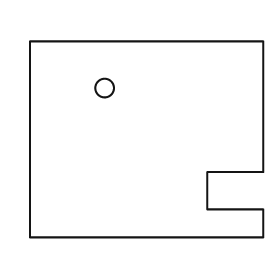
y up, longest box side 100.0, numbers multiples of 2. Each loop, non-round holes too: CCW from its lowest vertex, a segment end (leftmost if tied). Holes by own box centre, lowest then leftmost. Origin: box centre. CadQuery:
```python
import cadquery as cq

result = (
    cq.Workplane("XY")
    .moveTo(-50.0, -42.0)
    .lineTo(50.0, -42.0)
    .lineTo(50.0, -30.0)
    .lineTo(26.0, -30.0)
    .lineTo(26.0, -14.0)
    .lineTo(50.0, -14.0)
    .lineTo(50.0, 42.0)
    .lineTo(-50.0, 42.0)
    .close()
    .moveTo(-18.0, 22.0)
    .circle(4.0)
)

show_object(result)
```